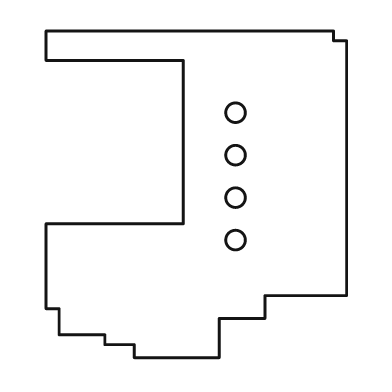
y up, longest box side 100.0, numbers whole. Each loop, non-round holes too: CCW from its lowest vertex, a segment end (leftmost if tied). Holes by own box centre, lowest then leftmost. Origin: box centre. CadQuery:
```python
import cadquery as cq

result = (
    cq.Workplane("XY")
    .moveTo(-19.0, -50.0)
    .lineTo(7.0, -50.0)
    .lineTo(7.0, -38.0)
    .lineTo(21.0, -38.0)
    .lineTo(21.0, -31.0)
    .lineTo(46.0, -31.0)
    .lineTo(46.0, 47.0)
    .lineTo(42.0, 47.0)
    .lineTo(42.0, 50.0)
    .lineTo(-46.0, 50.0)
    .lineTo(-46.0, 41.0)
    .lineTo(-4.0, 41.0)
    .lineTo(-4.0, -9.0)
    .lineTo(-46.0, -9.0)
    .lineTo(-46.0, -35.0)
    .lineTo(-42.0, -35.0)
    .lineTo(-42.0, -43.0)
    .lineTo(-28.0, -43.0)
    .lineTo(-28.0, -46.0)
    .lineTo(-19.0, -46.0)
    .close()
    .moveTo(12.0, -14.0)
    .circle(3.0)
    .moveTo(12.0, -1.0)
    .circle(3.0)
    .moveTo(12.0, 12.0)
    .circle(3.0)
    .moveTo(12.0, 25.0)
    .circle(3.0)
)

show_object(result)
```